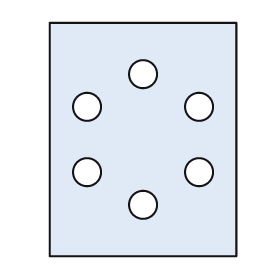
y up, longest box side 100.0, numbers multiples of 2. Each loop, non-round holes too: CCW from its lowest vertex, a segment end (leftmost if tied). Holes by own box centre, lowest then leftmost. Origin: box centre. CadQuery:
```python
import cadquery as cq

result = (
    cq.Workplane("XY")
    .moveTo(-40.0, -50.0)
    .lineTo(40.0, -50.0)
    .lineTo(40.0, 50.0)
    .lineTo(-40.0, 50.0)
    .close()
    .moveTo(0.0, -28.0)
    .circle(6.0)
    .moveTo(-24.0, -14.0)
    .circle(6.0)
    .moveTo(24.0, -14.0)
    .circle(6.0)
    .moveTo(-24.0, 14.0)
    .circle(6.0)
    .moveTo(24.0, 14.0)
    .circle(6.0)
    .moveTo(0.0, 28.0)
    .circle(6.0)
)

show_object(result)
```